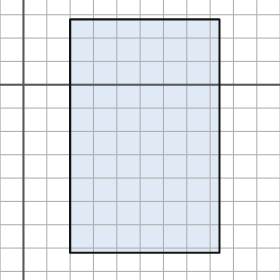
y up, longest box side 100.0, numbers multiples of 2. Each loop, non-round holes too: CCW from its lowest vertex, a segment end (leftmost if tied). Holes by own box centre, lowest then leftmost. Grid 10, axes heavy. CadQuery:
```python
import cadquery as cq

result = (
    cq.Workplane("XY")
    .moveTo(20.0, -72.0)
    .lineTo(84.0, -72.0)
    .lineTo(84.0, 28.0)
    .lineTo(20.0, 28.0)
    .close()
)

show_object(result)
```